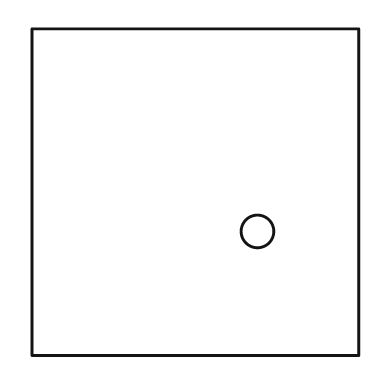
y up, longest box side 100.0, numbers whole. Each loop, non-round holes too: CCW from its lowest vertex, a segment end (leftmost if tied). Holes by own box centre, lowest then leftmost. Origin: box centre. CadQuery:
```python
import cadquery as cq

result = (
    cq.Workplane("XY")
    .moveTo(-50.0, -50.0)
    .lineTo(50.0, -50.0)
    .lineTo(50.0, 50.0)
    .lineTo(-50.0, 50.0)
    .close()
    .moveTo(19.0, -12.0)
    .circle(5.0)
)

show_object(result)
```